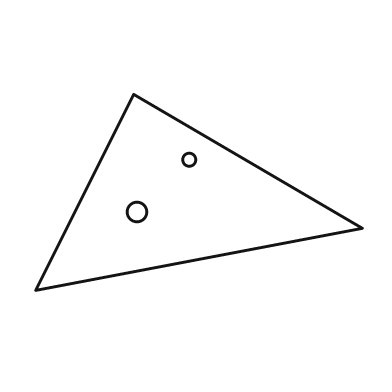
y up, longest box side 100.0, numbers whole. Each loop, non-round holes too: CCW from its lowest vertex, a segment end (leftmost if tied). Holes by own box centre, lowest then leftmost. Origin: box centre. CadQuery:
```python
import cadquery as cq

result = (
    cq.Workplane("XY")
    .moveTo(-50.0, -30.0)
    .lineTo(50.0, -11.0)
    .lineTo(-20.0, 30.0)
    .close()
    .moveTo(-19.0, -6.0)
    .circle(3.0)
    .moveTo(-3.0, 10.0)
    .circle(2.0)
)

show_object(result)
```